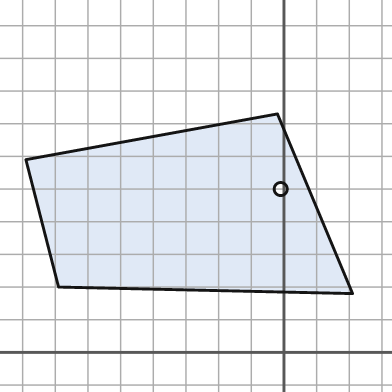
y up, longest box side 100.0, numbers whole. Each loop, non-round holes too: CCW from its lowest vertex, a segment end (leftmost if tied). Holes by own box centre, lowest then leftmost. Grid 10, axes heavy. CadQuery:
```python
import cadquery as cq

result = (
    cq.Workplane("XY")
    .moveTo(21.0, 18.0)
    .lineTo(-2.0, 73.0)
    .lineTo(-79.0, 59.0)
    .lineTo(-69.0, 20.0)
    .close()
    .moveTo(-1.0, 50.0)
    .circle(2.0)
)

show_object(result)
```